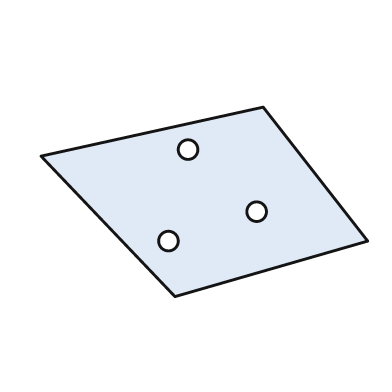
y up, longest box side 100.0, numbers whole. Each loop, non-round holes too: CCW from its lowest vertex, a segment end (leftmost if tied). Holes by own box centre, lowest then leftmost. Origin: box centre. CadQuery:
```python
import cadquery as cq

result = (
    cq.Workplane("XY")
    .moveTo(-9.0, -29.0)
    .lineTo(50.0, -12.0)
    .lineTo(18.0, 29.0)
    .lineTo(-50.0, 14.0)
    .close()
    .moveTo(-11.0, -12.0)
    .circle(3.0)
    .moveTo(16.0, -3.0)
    .circle(3.0)
    .moveTo(-5.0, 16.0)
    .circle(3.0)
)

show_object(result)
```